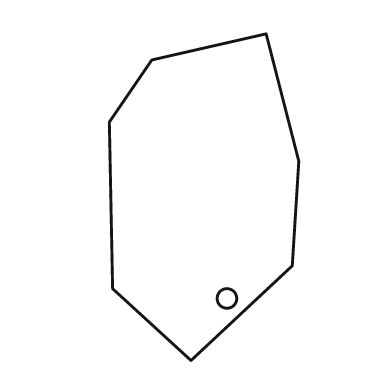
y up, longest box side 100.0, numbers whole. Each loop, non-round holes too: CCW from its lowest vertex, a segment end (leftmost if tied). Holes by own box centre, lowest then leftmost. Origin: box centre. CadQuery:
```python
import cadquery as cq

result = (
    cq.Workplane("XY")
    .moveTo(-4.0, -50.0)
    .lineTo(27.0, -21.0)
    .lineTo(29.0, 11.0)
    .lineTo(19.0, 50.0)
    .lineTo(-16.0, 42.0)
    .lineTo(-29.0, 23.0)
    .lineTo(-28.0, -28.0)
    .close()
    .moveTo(7.0, -31.0)
    .circle(3.0)
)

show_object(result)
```